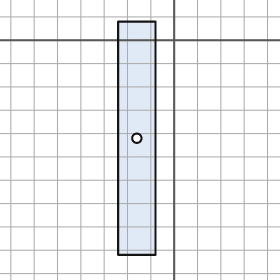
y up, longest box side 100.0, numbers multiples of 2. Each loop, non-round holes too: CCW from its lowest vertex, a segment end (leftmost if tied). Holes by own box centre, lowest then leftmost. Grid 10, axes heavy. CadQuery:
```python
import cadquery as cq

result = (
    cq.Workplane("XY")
    .moveTo(-24.0, -92.0)
    .lineTo(-8.0, -92.0)
    .lineTo(-8.0, 8.0)
    .lineTo(-24.0, 8.0)
    .close()
    .moveTo(-16.0, -42.0)
    .circle(2.0)
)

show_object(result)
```